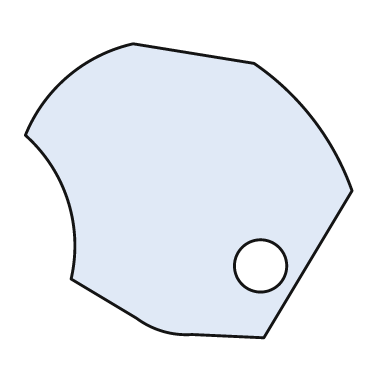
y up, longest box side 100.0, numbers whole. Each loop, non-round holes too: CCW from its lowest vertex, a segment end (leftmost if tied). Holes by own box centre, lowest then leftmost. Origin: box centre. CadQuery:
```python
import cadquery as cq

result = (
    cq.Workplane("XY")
    .moveTo(23.0, -45.0)
    .lineTo(50.0, 0.0)
    .threePointArc((38.0, 22.0), (20.0, 39.0))
    .lineTo(-17.0, 45.0)
    .threePointArc((-37.0, 35.0), (-50.0, 17.0))
    .threePointArc((-37.0, -3.0), (-36.0, -27.0))
    .lineTo(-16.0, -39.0)
    .threePointArc((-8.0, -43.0), (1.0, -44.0))
    .close()
    .moveTo(22.0, -23.0)
    .circle(8.0)
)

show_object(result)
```